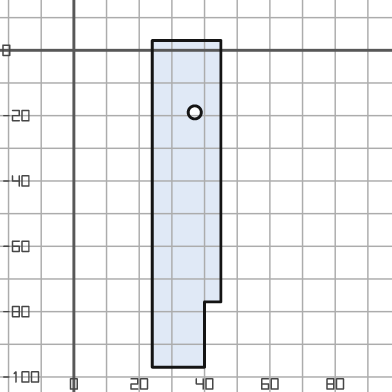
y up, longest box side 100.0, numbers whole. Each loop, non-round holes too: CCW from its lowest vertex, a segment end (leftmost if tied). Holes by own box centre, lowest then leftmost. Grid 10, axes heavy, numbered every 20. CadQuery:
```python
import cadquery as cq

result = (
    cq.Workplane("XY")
    .moveTo(24.0, -97.0)
    .lineTo(40.0, -97.0)
    .lineTo(40.0, -77.0)
    .lineTo(45.0, -77.0)
    .lineTo(45.0, 3.0)
    .lineTo(24.0, 3.0)
    .close()
    .moveTo(37.0, -19.0)
    .circle(2.0)
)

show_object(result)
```